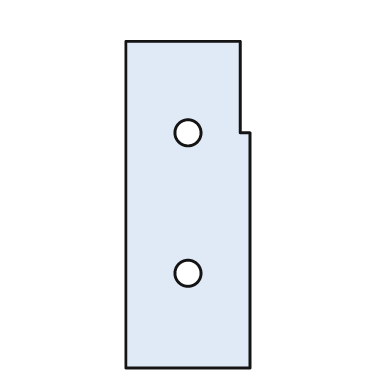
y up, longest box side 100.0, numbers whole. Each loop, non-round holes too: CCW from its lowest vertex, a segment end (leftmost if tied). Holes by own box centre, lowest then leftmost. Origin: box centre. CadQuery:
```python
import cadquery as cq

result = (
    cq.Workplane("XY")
    .moveTo(-19.0, -50.0)
    .lineTo(19.0, -50.0)
    .lineTo(19.0, 22.0)
    .lineTo(16.0, 22.0)
    .lineTo(16.0, 50.0)
    .lineTo(-19.0, 50.0)
    .close()
    .moveTo(0.0, -21.0)
    .circle(4.0)
    .moveTo(0.0, 22.0)
    .circle(4.0)
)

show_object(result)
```